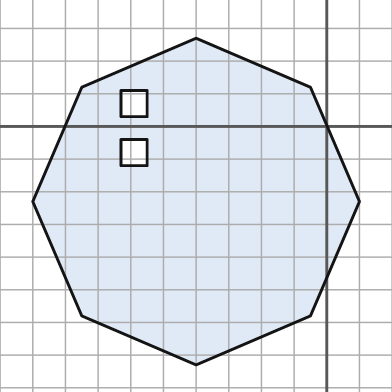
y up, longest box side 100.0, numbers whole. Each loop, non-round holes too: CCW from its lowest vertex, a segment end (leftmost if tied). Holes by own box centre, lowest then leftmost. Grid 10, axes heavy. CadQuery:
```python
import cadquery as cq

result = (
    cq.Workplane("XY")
    .moveTo(-40.0, -73.0)
    .lineTo(-5.0, -58.0)
    .lineTo(10.0, -23.0)
    .lineTo(-5.0, 12.0)
    .lineTo(-40.0, 27.0)
    .lineTo(-75.0, 12.0)
    .lineTo(-90.0, -23.0)
    .lineTo(-75.0, -58.0)
    .close()
    .moveTo(-63.0, -12.0)
    .lineTo(-55.0, -12.0)
    .lineTo(-55.0, -4.0)
    .lineTo(-63.0, -4.0)
    .close()
    .moveTo(-63.0, 3.0)
    .lineTo(-55.0, 3.0)
    .lineTo(-55.0, 11.0)
    .lineTo(-63.0, 11.0)
    .close()
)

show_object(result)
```